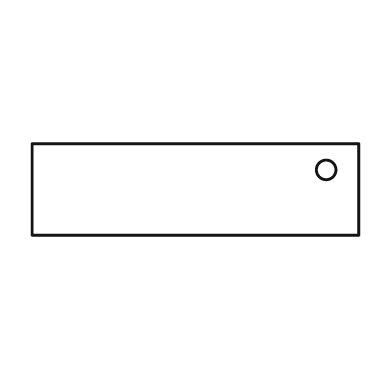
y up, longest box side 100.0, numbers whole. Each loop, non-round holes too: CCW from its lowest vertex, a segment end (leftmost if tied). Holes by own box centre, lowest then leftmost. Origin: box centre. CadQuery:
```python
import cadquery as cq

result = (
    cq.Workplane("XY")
    .moveTo(-50.0, -14.0)
    .lineTo(50.0, -14.0)
    .lineTo(50.0, 14.0)
    .lineTo(-50.0, 14.0)
    .close()
    .moveTo(40.0, 6.0)
    .circle(3.0)
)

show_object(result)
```